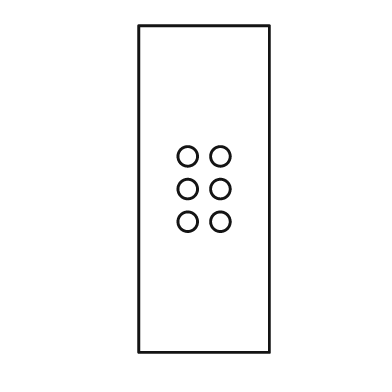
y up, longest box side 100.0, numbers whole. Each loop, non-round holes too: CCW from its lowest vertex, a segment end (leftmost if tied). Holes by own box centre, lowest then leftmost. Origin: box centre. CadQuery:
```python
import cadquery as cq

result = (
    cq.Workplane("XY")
    .moveTo(-20.0, -50.0)
    .lineTo(20.0, -50.0)
    .lineTo(20.0, 50.0)
    .lineTo(-20.0, 50.0)
    .close()
    .moveTo(-5.0, -10.0)
    .circle(3.0)
    .moveTo(5.0, -10.0)
    .circle(3.0)
    .moveTo(-5.0, 0.0)
    .circle(3.0)
    .moveTo(5.0, 0.0)
    .circle(3.0)
    .moveTo(-5.0, 10.0)
    .circle(3.0)
    .moveTo(5.0, 10.0)
    .circle(3.0)
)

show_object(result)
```